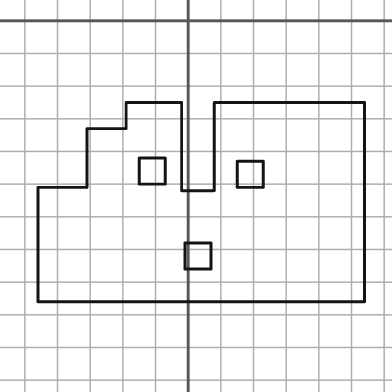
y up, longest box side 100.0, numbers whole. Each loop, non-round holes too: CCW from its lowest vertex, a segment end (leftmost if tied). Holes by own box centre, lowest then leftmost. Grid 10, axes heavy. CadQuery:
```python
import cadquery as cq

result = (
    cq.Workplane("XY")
    .moveTo(-46.0, -86.0)
    .lineTo(54.0, -86.0)
    .lineTo(54.0, -25.0)
    .lineTo(8.0, -25.0)
    .lineTo(8.0, -52.0)
    .lineTo(-2.0, -52.0)
    .lineTo(-2.0, -25.0)
    .lineTo(-19.0, -25.0)
    .lineTo(-19.0, -33.0)
    .lineTo(-31.0, -33.0)
    .lineTo(-31.0, -51.0)
    .lineTo(-46.0, -51.0)
    .close()
    .moveTo(-1.0, -76.0)
    .lineTo(7.0, -76.0)
    .lineTo(7.0, -68.0)
    .lineTo(-1.0, -68.0)
    .close()
    .moveTo(15.0, -51.0)
    .lineTo(23.0, -51.0)
    .lineTo(23.0, -43.0)
    .lineTo(15.0, -43.0)
    .close()
    .moveTo(-15.0, -50.0)
    .lineTo(-7.0, -50.0)
    .lineTo(-7.0, -42.0)
    .lineTo(-15.0, -42.0)
    .close()
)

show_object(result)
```